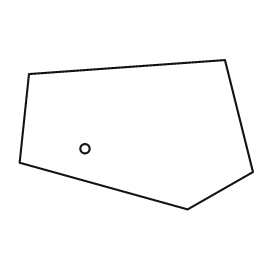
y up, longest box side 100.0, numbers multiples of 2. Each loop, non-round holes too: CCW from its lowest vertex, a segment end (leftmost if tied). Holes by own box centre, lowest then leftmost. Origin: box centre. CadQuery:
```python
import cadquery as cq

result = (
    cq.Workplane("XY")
    .moveTo(22.0, -32.0)
    .lineTo(50.0, -16.0)
    .lineTo(38.0, 32.0)
    .lineTo(-46.0, 26.0)
    .lineTo(-50.0, -12.0)
    .close()
    .moveTo(-22.0, -6.0)
    .circle(2.0)
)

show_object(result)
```